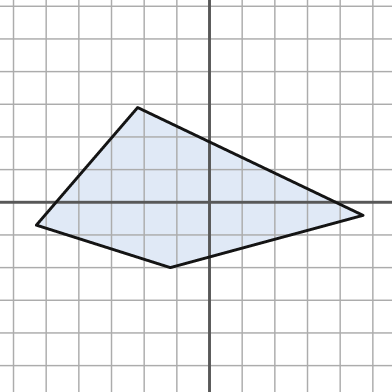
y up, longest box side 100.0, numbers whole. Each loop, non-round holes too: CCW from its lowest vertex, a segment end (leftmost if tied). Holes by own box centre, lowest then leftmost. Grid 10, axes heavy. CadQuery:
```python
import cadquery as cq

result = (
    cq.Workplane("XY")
    .moveTo(-12.0, -20.0)
    .lineTo(47.0, -4.0)
    .lineTo(-22.0, 29.0)
    .lineTo(-53.0, -7.0)
    .close()
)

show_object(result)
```